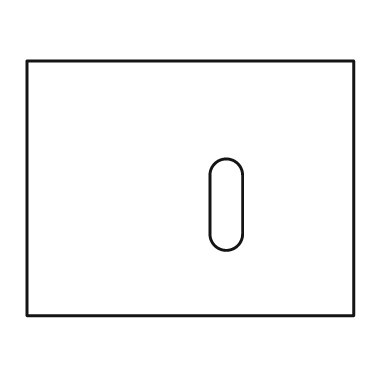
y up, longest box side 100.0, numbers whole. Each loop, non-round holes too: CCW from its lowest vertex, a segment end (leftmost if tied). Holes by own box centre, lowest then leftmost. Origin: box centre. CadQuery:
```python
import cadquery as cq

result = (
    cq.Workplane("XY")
    .moveTo(-50.0, -39.0)
    .lineTo(50.0, -39.0)
    .lineTo(50.0, 39.0)
    .lineTo(-50.0, 39.0)
    .close()
    .moveTo(6.0, -14.0)
    .threePointArc((11.0, -19.0), (16.0, -14.0))
    .lineTo(16.0, 4.0)
    .threePointArc((11.0, 9.0), (6.0, 4.0))
    .close()
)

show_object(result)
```